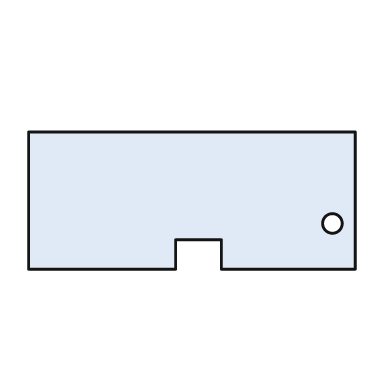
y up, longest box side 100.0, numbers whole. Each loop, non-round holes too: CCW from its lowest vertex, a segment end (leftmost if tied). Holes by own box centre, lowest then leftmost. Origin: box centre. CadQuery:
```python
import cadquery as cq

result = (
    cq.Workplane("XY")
    .moveTo(-50.0, -21.0)
    .lineTo(-5.0, -21.0)
    .lineTo(-5.0, -12.0)
    .lineTo(9.0, -12.0)
    .lineTo(9.0, -21.0)
    .lineTo(50.0, -21.0)
    .lineTo(50.0, 21.0)
    .lineTo(-50.0, 21.0)
    .close()
    .moveTo(43.0, -7.0)
    .circle(3.0)
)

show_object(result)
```